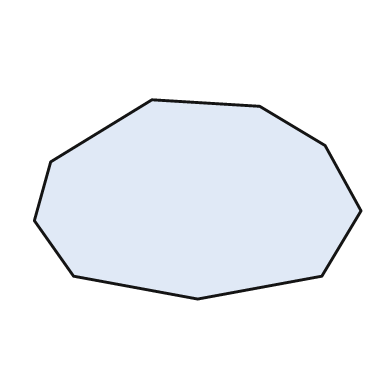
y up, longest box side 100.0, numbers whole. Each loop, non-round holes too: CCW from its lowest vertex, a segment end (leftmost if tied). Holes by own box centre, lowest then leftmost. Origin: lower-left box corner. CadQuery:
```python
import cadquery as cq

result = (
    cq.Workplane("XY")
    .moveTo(50.0, 0.0)
    .lineTo(88.0, 7.0)
    .lineTo(100.0, 27.0)
    .lineTo(89.0, 47.0)
    .lineTo(69.0, 59.0)
    .lineTo(36.0, 61.0)
    .lineTo(5.0, 42.0)
    .lineTo(0.0, 24.0)
    .lineTo(12.0, 7.0)
    .close()
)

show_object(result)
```